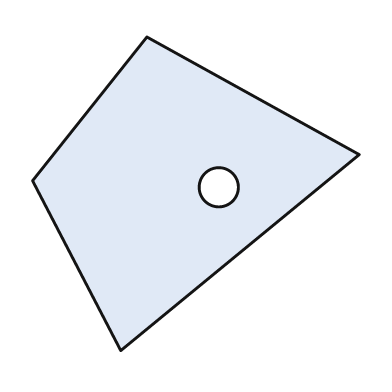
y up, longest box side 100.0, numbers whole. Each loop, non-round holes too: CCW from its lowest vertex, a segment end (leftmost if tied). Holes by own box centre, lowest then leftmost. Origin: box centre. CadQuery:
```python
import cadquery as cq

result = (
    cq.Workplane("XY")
    .moveTo(-23.0, -48.0)
    .lineTo(50.0, 12.0)
    .lineTo(-15.0, 48.0)
    .lineTo(-50.0, 4.0)
    .close()
    .moveTo(7.0, 2.0)
    .circle(6.0)
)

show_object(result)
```